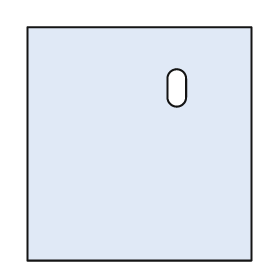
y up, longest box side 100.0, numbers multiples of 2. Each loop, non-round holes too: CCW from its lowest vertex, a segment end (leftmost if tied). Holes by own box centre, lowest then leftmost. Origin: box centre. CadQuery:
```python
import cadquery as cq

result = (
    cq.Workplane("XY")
    .moveTo(-48.0, -50.0)
    .lineTo(48.0, -50.0)
    .lineTo(48.0, 50.0)
    .lineTo(-48.0, 50.0)
    .close()
    .moveTo(12.0, 20.0)
    .threePointArc((16.0, 16.0), (20.0, 20.0))
    .lineTo(20.0, 28.0)
    .threePointArc((16.0, 32.0), (12.0, 28.0))
    .close()
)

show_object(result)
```